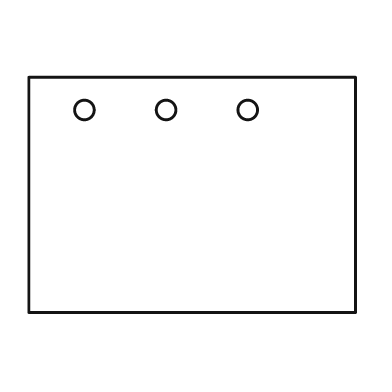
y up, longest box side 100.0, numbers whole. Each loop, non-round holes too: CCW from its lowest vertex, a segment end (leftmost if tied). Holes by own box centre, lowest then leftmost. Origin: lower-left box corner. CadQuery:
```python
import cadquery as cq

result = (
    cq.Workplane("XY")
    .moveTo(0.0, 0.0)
    .lineTo(100.0, 0.0)
    .lineTo(100.0, 72.0)
    .lineTo(0.0, 72.0)
    .close()
    .moveTo(17.0, 62.0)
    .circle(3.0)
    .moveTo(42.0, 62.0)
    .circle(3.0)
    .moveTo(67.0, 62.0)
    .circle(3.0)
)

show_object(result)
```